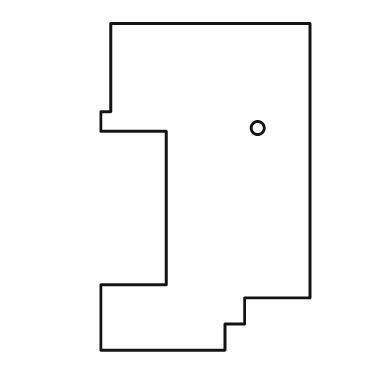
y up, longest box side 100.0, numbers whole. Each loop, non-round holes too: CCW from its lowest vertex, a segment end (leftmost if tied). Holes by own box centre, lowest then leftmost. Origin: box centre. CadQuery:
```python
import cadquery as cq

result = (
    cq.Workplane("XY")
    .moveTo(-32.0, -50.0)
    .lineTo(6.0, -50.0)
    .lineTo(6.0, -42.0)
    .lineTo(12.0, -42.0)
    .lineTo(12.0, -34.0)
    .lineTo(32.0, -34.0)
    .lineTo(32.0, 50.0)
    .lineTo(-29.0, 50.0)
    .lineTo(-29.0, 23.0)
    .lineTo(-32.0, 23.0)
    .lineTo(-32.0, 17.0)
    .lineTo(-12.0, 17.0)
    .lineTo(-12.0, -30.0)
    .lineTo(-32.0, -30.0)
    .close()
    .moveTo(16.0, 18.0)
    .circle(2.0)
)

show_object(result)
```